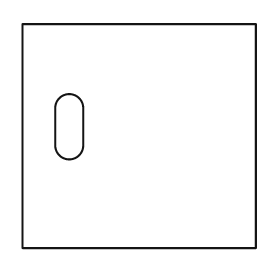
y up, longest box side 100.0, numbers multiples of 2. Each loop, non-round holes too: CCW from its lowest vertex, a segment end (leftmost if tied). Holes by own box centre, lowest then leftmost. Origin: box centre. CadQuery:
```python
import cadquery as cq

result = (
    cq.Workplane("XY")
    .moveTo(-50.0, -48.0)
    .lineTo(50.0, -48.0)
    .lineTo(50.0, 48.0)
    .lineTo(-50.0, 48.0)
    .close()
    .moveTo(-36.0, -4.0)
    .threePointArc((-30.0, -10.0), (-24.0, -4.0))
    .lineTo(-24.0, 12.0)
    .threePointArc((-30.0, 18.0), (-36.0, 12.0))
    .close()
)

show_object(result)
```